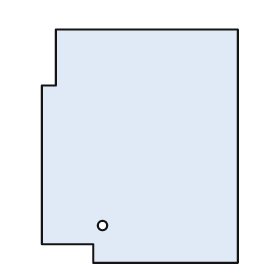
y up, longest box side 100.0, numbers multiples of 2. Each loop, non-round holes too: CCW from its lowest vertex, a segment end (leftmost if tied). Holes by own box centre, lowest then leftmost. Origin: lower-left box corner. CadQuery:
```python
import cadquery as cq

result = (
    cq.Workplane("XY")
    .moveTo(22.0, 0.0)
    .lineTo(84.0, 0.0)
    .lineTo(84.0, 100.0)
    .lineTo(6.0, 100.0)
    .lineTo(6.0, 76.0)
    .lineTo(0.0, 76.0)
    .lineTo(0.0, 8.0)
    .lineTo(22.0, 8.0)
    .close()
    .moveTo(26.0, 16.0)
    .circle(2.0)
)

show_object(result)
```